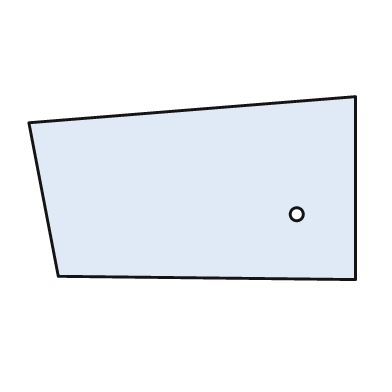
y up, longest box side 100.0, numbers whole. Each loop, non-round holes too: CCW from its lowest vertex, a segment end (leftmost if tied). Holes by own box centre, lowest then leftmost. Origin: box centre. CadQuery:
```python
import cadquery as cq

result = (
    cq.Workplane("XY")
    .moveTo(50.0, -28.0)
    .lineTo(50.0, 28.0)
    .lineTo(-50.0, 20.0)
    .lineTo(-41.0, -27.0)
    .close()
    .moveTo(32.0, -8.0)
    .circle(2.0)
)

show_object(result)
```